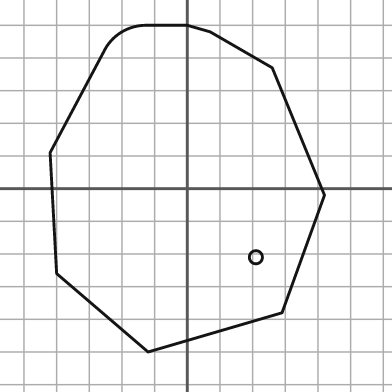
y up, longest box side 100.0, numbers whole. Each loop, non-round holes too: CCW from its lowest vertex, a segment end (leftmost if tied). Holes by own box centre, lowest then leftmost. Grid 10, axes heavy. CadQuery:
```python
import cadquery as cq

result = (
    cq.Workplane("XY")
    .moveTo(-12.0, -50.0)
    .lineTo(29.0, -38.0)
    .lineTo(42.0, -2.0)
    .lineTo(26.0, 37.0)
    .lineTo(7.0, 48.0)
    .lineTo(0.0, 50.0)
    .lineTo(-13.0, 50.0)
    .threePointArc((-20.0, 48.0), (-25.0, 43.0))
    .lineTo(-42.0, 11.0)
    .lineTo(-40.0, -26.0)
    .close()
    .moveTo(21.0, -21.0)
    .circle(2.0)
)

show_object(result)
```